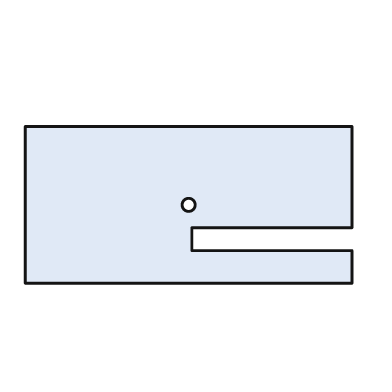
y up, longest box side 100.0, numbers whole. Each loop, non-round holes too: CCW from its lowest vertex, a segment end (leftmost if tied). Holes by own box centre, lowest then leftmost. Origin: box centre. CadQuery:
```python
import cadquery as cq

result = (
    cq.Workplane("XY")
    .moveTo(-50.0, -24.0)
    .lineTo(50.0, -24.0)
    .lineTo(50.0, -14.0)
    .lineTo(1.0, -14.0)
    .lineTo(1.0, -7.0)
    .lineTo(50.0, -7.0)
    .lineTo(50.0, 24.0)
    .lineTo(-50.0, 24.0)
    .close()
    .moveTo(0.0, 0.0)
    .circle(2.0)
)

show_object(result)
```